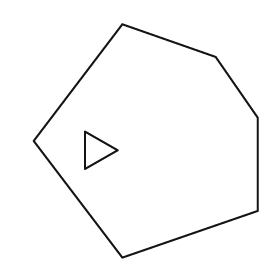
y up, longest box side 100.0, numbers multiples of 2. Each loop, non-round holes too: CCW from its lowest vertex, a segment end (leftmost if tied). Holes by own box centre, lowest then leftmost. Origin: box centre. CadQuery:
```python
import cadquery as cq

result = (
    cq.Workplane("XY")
    .moveTo(-10.0, -50.0)
    .lineTo(48.0, -30.0)
    .lineTo(48.0, 10.0)
    .lineTo(30.0, 36.0)
    .lineTo(-10.0, 50.0)
    .lineTo(-48.0, 0.0)
    .close()
    .moveTo(-26.0, -12.0)
    .lineTo(-12.0, -4.0)
    .lineTo(-26.0, 4.0)
    .close()
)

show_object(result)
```